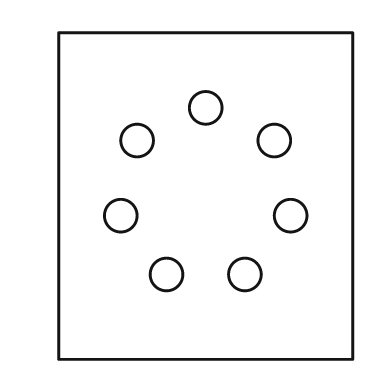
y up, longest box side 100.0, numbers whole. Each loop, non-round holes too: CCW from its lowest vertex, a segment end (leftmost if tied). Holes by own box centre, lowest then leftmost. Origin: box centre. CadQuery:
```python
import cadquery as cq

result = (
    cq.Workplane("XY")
    .moveTo(-45.0, -50.0)
    .lineTo(45.0, -50.0)
    .lineTo(45.0, 50.0)
    .lineTo(-45.0, 50.0)
    .close()
    .moveTo(-12.0, -24.0)
    .circle(5.0)
    .moveTo(12.0, -24.0)
    .circle(5.0)
    .moveTo(-26.0, -6.0)
    .circle(5.0)
    .moveTo(26.0, -6.0)
    .circle(5.0)
    .moveTo(-21.0, 17.0)
    .circle(5.0)
    .moveTo(21.0, 17.0)
    .circle(5.0)
    .moveTo(0.0, 27.0)
    .circle(5.0)
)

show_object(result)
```